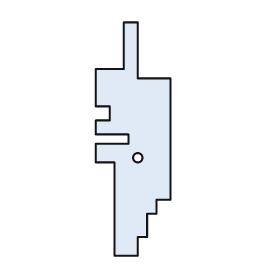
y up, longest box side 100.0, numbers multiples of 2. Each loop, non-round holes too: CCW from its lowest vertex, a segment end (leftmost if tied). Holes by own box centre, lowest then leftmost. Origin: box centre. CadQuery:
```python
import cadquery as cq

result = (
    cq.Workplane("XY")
    .moveTo(-8.0, -50.0)
    .lineTo(2.0, -50.0)
    .lineTo(2.0, -42.0)
    .lineTo(6.0, -42.0)
    .lineTo(6.0, -32.0)
    .lineTo(10.0, -32.0)
    .lineTo(10.0, -26.0)
    .lineTo(16.0, -26.0)
    .lineTo(16.0, 26.0)
    .lineTo(2.0, 26.0)
    .lineTo(2.0, 50.0)
    .lineTo(-4.0, 50.0)
    .lineTo(-4.0, 30.0)
    .lineTo(-16.0, 30.0)
    .lineTo(-16.0, 14.0)
    .lineTo(-10.0, 14.0)
    .lineTo(-10.0, 8.0)
    .lineTo(-16.0, 8.0)
    .lineTo(-16.0, 2.0)
    .lineTo(-2.0, 2.0)
    .lineTo(-2.0, -2.0)
    .lineTo(-16.0, -2.0)
    .lineTo(-16.0, -10.0)
    .lineTo(-8.0, -10.0)
    .close()
    .moveTo(2.0, -8.0)
    .circle(2.0)
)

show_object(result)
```